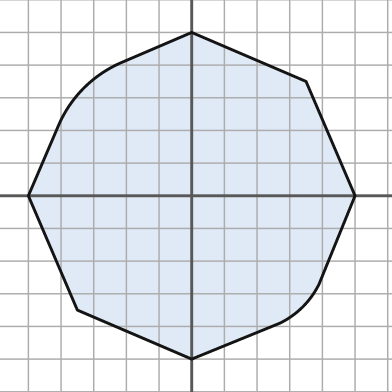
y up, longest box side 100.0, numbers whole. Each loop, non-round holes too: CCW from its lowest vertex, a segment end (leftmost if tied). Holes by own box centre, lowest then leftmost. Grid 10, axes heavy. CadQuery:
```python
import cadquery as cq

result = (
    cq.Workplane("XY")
    .moveTo(0.0, -50.0)
    .lineTo(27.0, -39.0)
    .threePointArc((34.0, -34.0), (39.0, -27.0))
    .lineTo(50.0, 0.0)
    .lineTo(35.0, 35.0)
    .lineTo(0.0, 50.0)
    .lineTo(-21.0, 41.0)
    .threePointArc((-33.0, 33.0), (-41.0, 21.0))
    .lineTo(-50.0, 0.0)
    .lineTo(-35.0, -35.0)
    .close()
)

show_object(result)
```